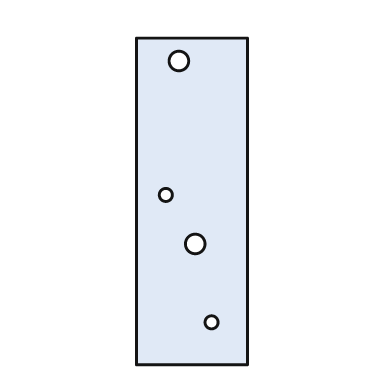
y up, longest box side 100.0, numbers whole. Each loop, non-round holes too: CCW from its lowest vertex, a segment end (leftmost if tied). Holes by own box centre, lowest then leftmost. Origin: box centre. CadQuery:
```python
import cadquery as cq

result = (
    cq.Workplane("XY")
    .moveTo(-17.0, -50.0)
    .lineTo(17.0, -50.0)
    .lineTo(17.0, 50.0)
    .lineTo(-17.0, 50.0)
    .close()
    .moveTo(6.0, -37.0)
    .circle(2.0)
    .moveTo(1.0, -13.0)
    .circle(3.0)
    .moveTo(-8.0, 2.0)
    .circle(2.0)
    .moveTo(-4.0, 43.0)
    .circle(3.0)
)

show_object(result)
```